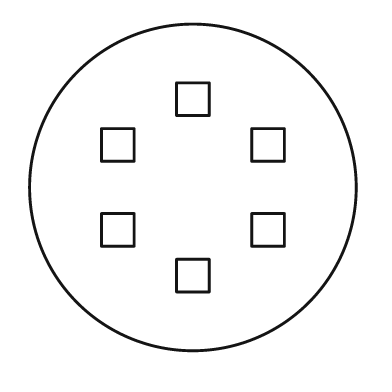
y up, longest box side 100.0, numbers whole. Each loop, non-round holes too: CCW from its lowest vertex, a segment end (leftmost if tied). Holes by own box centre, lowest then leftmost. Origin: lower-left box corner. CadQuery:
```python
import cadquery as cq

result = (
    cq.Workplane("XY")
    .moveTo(50.0, 50.0)
    .circle(50.0)
    .moveTo(45.0, 18.0)
    .lineTo(55.0, 18.0)
    .lineTo(55.0, 28.0)
    .lineTo(45.0, 28.0)
    .close()
    .moveTo(22.0, 32.0)
    .lineTo(32.0, 32.0)
    .lineTo(32.0, 42.0)
    .lineTo(22.0, 42.0)
    .close()
    .moveTo(68.0, 32.0)
    .lineTo(78.0, 32.0)
    .lineTo(78.0, 42.0)
    .lineTo(68.0, 42.0)
    .close()
    .moveTo(22.0, 58.0)
    .lineTo(32.0, 58.0)
    .lineTo(32.0, 68.0)
    .lineTo(22.0, 68.0)
    .close()
    .moveTo(68.0, 58.0)
    .lineTo(78.0, 58.0)
    .lineTo(78.0, 68.0)
    .lineTo(68.0, 68.0)
    .close()
    .moveTo(45.0, 72.0)
    .lineTo(55.0, 72.0)
    .lineTo(55.0, 82.0)
    .lineTo(45.0, 82.0)
    .close()
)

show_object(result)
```